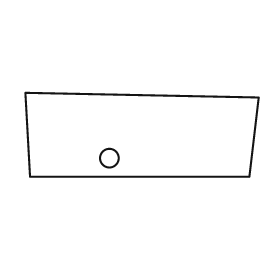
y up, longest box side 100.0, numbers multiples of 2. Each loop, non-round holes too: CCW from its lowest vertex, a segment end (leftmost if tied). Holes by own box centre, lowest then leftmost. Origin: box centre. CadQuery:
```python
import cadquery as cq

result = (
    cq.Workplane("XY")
    .moveTo(-48.0, -18.0)
    .lineTo(46.0, -18.0)
    .lineTo(50.0, 16.0)
    .lineTo(-50.0, 18.0)
    .close()
    .moveTo(-14.0, -10.0)
    .circle(4.0)
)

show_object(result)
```